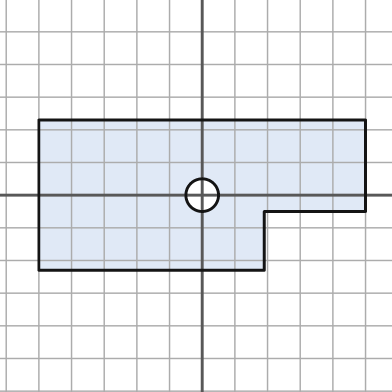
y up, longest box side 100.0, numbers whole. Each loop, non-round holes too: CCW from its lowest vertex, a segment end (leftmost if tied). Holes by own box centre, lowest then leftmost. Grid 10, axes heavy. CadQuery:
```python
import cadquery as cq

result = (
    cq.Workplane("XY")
    .moveTo(-50.0, -23.0)
    .lineTo(19.0, -23.0)
    .lineTo(19.0, -5.0)
    .lineTo(50.0, -5.0)
    .lineTo(50.0, 23.0)
    .lineTo(-50.0, 23.0)
    .close()
    .moveTo(0.0, 0.0)
    .circle(5.0)
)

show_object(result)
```